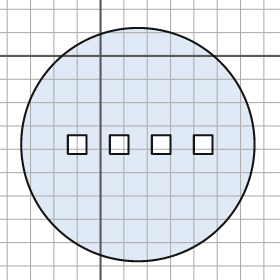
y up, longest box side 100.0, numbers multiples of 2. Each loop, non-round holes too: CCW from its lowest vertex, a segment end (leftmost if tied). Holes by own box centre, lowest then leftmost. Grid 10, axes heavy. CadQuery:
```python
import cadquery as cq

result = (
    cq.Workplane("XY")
    .moveTo(16.0, -38.0)
    .circle(50.0)
    .moveTo(-14.0, -42.0)
    .lineTo(-6.0, -42.0)
    .lineTo(-6.0, -34.0)
    .lineTo(-14.0, -34.0)
    .close()
    .moveTo(4.0, -42.0)
    .lineTo(12.0, -42.0)
    .lineTo(12.0, -34.0)
    .lineTo(4.0, -34.0)
    .close()
    .moveTo(22.0, -42.0)
    .lineTo(30.0, -42.0)
    .lineTo(30.0, -34.0)
    .lineTo(22.0, -34.0)
    .close()
    .moveTo(40.0, -42.0)
    .lineTo(48.0, -42.0)
    .lineTo(48.0, -34.0)
    .lineTo(40.0, -34.0)
    .close()
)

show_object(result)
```